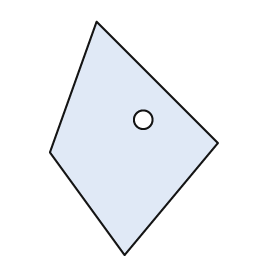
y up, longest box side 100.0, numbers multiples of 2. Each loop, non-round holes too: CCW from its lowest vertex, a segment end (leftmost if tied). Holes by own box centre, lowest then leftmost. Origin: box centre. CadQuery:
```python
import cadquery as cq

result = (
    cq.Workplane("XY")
    .moveTo(-4.0, -50.0)
    .lineTo(36.0, -2.0)
    .lineTo(-16.0, 50.0)
    .lineTo(-36.0, -6.0)
    .close()
    .moveTo(4.0, 8.0)
    .circle(4.0)
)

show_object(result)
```